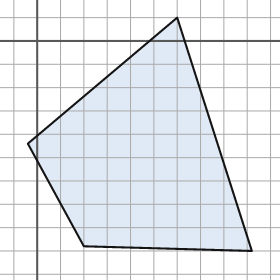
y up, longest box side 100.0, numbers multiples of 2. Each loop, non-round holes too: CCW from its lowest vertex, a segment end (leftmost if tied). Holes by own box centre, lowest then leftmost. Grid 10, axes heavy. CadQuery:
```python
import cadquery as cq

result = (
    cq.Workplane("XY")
    .moveTo(92.0, -90.0)
    .lineTo(60.0, 10.0)
    .lineTo(-4.0, -44.0)
    .lineTo(20.0, -88.0)
    .close()
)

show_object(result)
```